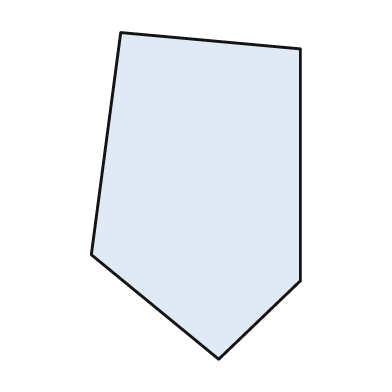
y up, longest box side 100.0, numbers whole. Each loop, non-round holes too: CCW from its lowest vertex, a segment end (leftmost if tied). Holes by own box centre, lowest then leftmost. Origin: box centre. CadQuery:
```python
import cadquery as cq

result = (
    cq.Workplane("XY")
    .moveTo(7.0, -50.0)
    .lineTo(32.0, -26.0)
    .lineTo(32.0, 45.0)
    .lineTo(-23.0, 50.0)
    .lineTo(-32.0, -18.0)
    .close()
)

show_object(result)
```